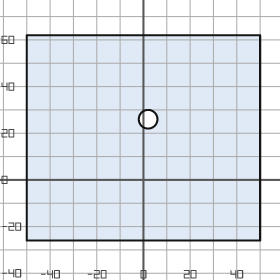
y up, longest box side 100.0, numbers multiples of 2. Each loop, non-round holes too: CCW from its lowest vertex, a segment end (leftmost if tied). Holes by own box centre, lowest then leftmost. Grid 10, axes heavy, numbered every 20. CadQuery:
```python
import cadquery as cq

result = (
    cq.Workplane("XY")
    .moveTo(-50.0, -26.0)
    .lineTo(50.0, -26.0)
    .lineTo(50.0, 62.0)
    .lineTo(-50.0, 62.0)
    .close()
    .moveTo(2.0, 26.0)
    .circle(4.0)
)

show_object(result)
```